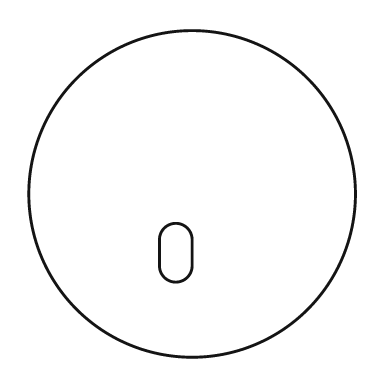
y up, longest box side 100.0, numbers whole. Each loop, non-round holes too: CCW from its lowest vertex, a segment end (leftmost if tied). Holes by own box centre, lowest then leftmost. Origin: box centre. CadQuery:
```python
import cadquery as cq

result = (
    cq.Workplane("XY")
    .moveTo(0.0, 0.0)
    .circle(50.0)
    .moveTo(-10.0, -22.0)
    .threePointArc((-5.0, -27.0), (0.0, -22.0))
    .lineTo(0.0, -14.0)
    .threePointArc((-5.0, -9.0), (-10.0, -14.0))
    .close()
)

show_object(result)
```